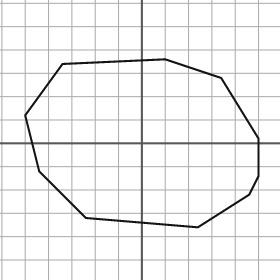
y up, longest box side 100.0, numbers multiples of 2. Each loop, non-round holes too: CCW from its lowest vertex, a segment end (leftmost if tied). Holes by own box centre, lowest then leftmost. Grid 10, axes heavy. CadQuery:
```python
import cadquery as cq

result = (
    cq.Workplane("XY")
    .moveTo(24.0, -36.0)
    .lineTo(46.0, -22.0)
    .lineTo(50.0, -14.0)
    .lineTo(50.0, 2.0)
    .lineTo(34.0, 28.0)
    .lineTo(10.0, 36.0)
    .lineTo(-34.0, 34.0)
    .lineTo(-50.0, 12.0)
    .lineTo(-44.0, -12.0)
    .lineTo(-24.0, -32.0)
    .close()
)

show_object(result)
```